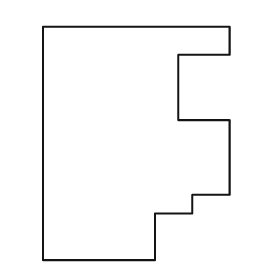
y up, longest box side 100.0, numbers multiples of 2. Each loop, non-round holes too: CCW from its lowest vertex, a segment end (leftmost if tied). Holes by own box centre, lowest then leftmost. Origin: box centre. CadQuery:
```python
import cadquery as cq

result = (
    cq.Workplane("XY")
    .moveTo(-40.0, -50.0)
    .lineTo(8.0, -50.0)
    .lineTo(8.0, -30.0)
    .lineTo(24.0, -30.0)
    .lineTo(24.0, -22.0)
    .lineTo(40.0, -22.0)
    .lineTo(40.0, 10.0)
    .lineTo(18.0, 10.0)
    .lineTo(18.0, 38.0)
    .lineTo(40.0, 38.0)
    .lineTo(40.0, 50.0)
    .lineTo(-40.0, 50.0)
    .close()
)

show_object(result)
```